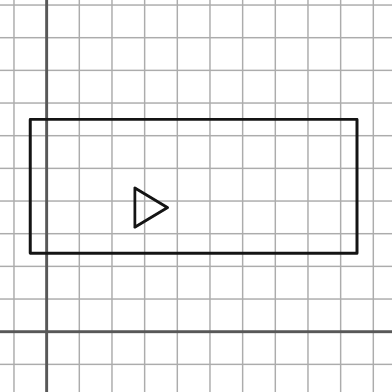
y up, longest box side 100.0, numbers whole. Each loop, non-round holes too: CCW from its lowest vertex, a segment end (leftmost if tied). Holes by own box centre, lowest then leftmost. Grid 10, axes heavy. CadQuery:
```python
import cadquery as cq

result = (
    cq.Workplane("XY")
    .moveTo(-5.0, 24.0)
    .lineTo(95.0, 24.0)
    .lineTo(95.0, 65.0)
    .lineTo(-5.0, 65.0)
    .close()
    .moveTo(27.0, 32.0)
    .lineTo(37.0, 38.0)
    .lineTo(27.0, 44.0)
    .close()
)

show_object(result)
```